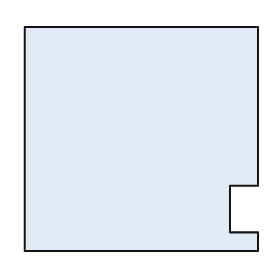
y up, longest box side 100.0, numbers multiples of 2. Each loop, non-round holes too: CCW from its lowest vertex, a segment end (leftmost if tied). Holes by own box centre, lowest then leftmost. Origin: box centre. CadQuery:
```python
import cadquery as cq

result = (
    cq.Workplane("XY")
    .moveTo(-50.0, -48.0)
    .lineTo(50.0, -48.0)
    .lineTo(50.0, -40.0)
    .lineTo(38.0, -40.0)
    .lineTo(38.0, -20.0)
    .lineTo(50.0, -20.0)
    .lineTo(50.0, 48.0)
    .lineTo(-50.0, 48.0)
    .close()
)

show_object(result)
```